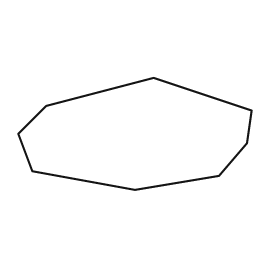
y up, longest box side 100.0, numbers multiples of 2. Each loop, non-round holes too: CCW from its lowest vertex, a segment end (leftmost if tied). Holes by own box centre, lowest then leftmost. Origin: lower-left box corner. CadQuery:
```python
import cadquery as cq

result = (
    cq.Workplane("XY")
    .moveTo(50.0, 0.0)
    .lineTo(86.0, 6.0)
    .lineTo(98.0, 20.0)
    .lineTo(100.0, 34.0)
    .lineTo(58.0, 48.0)
    .lineTo(12.0, 36.0)
    .lineTo(0.0, 24.0)
    .lineTo(6.0, 8.0)
    .close()
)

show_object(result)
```